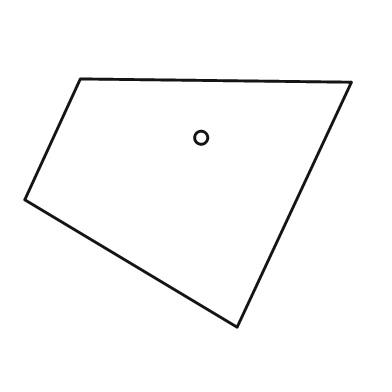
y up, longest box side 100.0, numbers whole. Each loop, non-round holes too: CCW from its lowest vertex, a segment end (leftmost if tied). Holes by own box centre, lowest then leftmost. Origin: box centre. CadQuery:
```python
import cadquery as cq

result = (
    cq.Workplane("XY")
    .moveTo(15.0, -38.0)
    .lineTo(50.0, 37.0)
    .lineTo(-33.0, 38.0)
    .lineTo(-50.0, 1.0)
    .close()
    .moveTo(4.0, 20.0)
    .circle(2.0)
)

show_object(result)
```